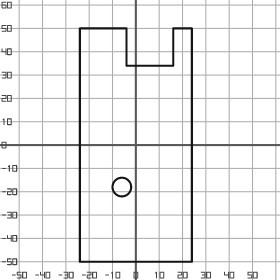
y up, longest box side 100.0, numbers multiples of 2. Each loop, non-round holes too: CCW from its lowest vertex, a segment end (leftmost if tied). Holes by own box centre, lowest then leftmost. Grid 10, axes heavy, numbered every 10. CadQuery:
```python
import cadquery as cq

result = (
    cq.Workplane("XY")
    .moveTo(-24.0, -50.0)
    .lineTo(24.0, -50.0)
    .lineTo(24.0, 50.0)
    .lineTo(16.0, 50.0)
    .lineTo(16.0, 34.0)
    .lineTo(-4.0, 34.0)
    .lineTo(-4.0, 50.0)
    .lineTo(-24.0, 50.0)
    .close()
    .moveTo(-6.0, -18.0)
    .circle(4.0)
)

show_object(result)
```